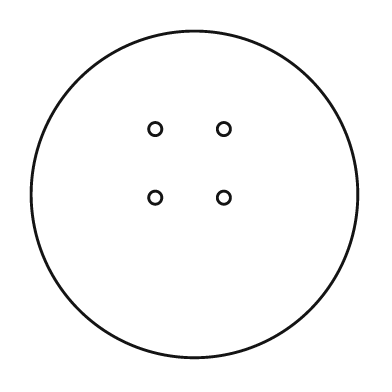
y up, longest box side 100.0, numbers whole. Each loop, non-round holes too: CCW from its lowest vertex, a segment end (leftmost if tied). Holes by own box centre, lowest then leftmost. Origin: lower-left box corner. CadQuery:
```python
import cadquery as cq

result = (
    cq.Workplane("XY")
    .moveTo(50.0, 50.0)
    .circle(50.0)
    .moveTo(38.0, 49.0)
    .circle(2.0)
    .moveTo(59.0, 49.0)
    .circle(2.0)
    .moveTo(38.0, 70.0)
    .circle(2.0)
    .moveTo(59.0, 70.0)
    .circle(2.0)
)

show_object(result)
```